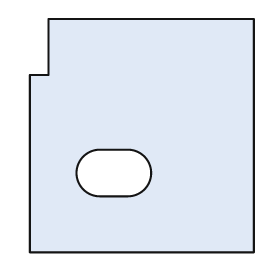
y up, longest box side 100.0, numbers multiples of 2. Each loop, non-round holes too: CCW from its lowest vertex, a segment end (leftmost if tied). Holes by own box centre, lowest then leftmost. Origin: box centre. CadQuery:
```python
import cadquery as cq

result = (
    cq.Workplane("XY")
    .moveTo(-48.0, -50.0)
    .lineTo(48.0, -50.0)
    .lineTo(48.0, 50.0)
    .lineTo(-40.0, 50.0)
    .lineTo(-40.0, 26.0)
    .lineTo(-48.0, 26.0)
    .close()
    .moveTo(-18.0, -26.0)
    .lineTo(-6.0, -26.0)
    .threePointArc((4.0, -16.0), (-6.0, -6.0))
    .lineTo(-18.0, -6.0)
    .threePointArc((-28.0, -16.0), (-18.0, -26.0))
    .close()
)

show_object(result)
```